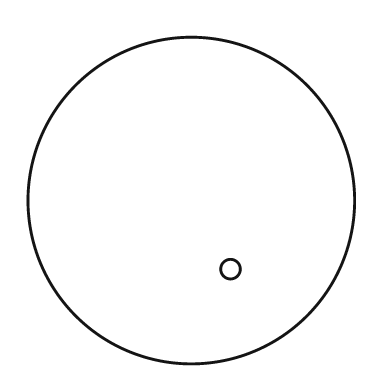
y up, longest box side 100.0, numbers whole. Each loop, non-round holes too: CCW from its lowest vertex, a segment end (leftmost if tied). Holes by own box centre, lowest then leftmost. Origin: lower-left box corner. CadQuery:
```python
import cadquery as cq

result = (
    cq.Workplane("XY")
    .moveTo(50.0, 50.0)
    .circle(50.0)
    .moveTo(62.0, 29.0)
    .circle(3.0)
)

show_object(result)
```